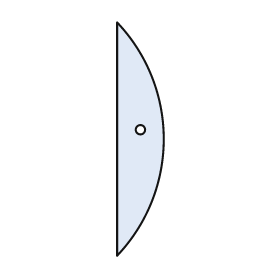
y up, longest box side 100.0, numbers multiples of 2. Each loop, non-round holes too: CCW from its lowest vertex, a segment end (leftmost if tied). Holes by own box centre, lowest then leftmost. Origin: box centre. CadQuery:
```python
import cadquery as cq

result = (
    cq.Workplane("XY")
    .moveTo(-10.0, -50.0)
    .threePointArc((10.0, 0.0), (-10.0, 50.0))
    .close()
    .moveTo(0.0, 4.0)
    .circle(2.0)
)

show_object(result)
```